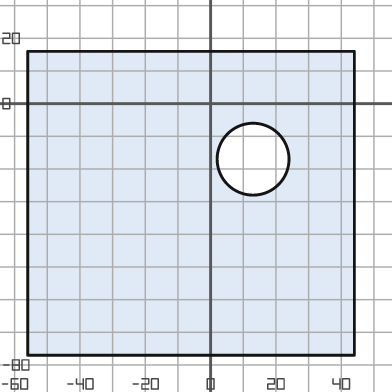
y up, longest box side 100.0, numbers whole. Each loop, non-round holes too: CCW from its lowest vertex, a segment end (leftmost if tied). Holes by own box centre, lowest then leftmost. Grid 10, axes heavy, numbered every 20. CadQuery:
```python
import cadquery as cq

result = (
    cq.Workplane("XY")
    .moveTo(-56.0, -77.0)
    .lineTo(44.0, -77.0)
    .lineTo(44.0, 16.0)
    .lineTo(-56.0, 16.0)
    .close()
    .moveTo(13.0, -17.0)
    .circle(11.0)
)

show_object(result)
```